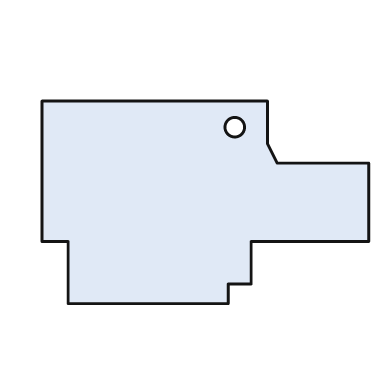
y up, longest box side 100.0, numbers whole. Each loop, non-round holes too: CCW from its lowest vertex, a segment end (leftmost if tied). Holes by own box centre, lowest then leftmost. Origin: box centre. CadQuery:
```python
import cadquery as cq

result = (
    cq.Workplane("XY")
    .moveTo(-42.0, -31.0)
    .lineTo(7.0, -31.0)
    .lineTo(7.0, -25.0)
    .lineTo(14.0, -25.0)
    .lineTo(14.0, -12.0)
    .lineTo(50.0, -12.0)
    .lineTo(50.0, 12.0)
    .lineTo(22.0, 12.0)
    .lineTo(19.0, 18.0)
    .lineTo(19.0, 31.0)
    .lineTo(-50.0, 31.0)
    .lineTo(-50.0, -12.0)
    .lineTo(-42.0, -12.0)
    .close()
    .moveTo(9.0, 23.0)
    .circle(3.0)
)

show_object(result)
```